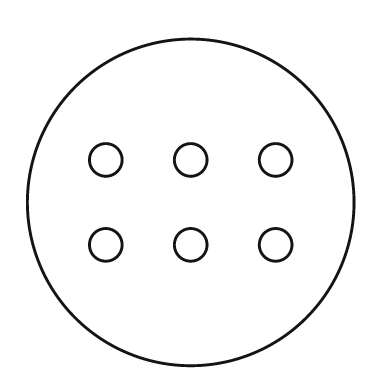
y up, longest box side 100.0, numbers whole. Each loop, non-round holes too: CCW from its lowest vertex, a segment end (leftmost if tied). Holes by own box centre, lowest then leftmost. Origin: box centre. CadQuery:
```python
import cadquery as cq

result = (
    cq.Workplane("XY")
    .moveTo(0.0, 0.0)
    .circle(50.0)
    .moveTo(-26.0, -13.0)
    .circle(5.0)
    .moveTo(0.0, -13.0)
    .circle(5.0)
    .moveTo(26.0, -13.0)
    .circle(5.0)
    .moveTo(-26.0, 13.0)
    .circle(5.0)
    .moveTo(0.0, 13.0)
    .circle(5.0)
    .moveTo(26.0, 13.0)
    .circle(5.0)
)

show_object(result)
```